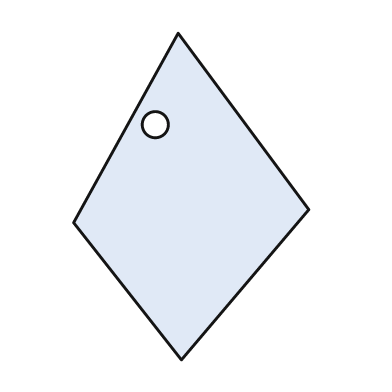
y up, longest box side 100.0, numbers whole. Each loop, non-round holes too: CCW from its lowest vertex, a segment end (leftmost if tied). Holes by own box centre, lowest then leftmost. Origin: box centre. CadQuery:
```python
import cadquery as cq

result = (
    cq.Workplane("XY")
    .moveTo(-3.0, -50.0)
    .lineTo(36.0, -4.0)
    .lineTo(-4.0, 50.0)
    .lineTo(-36.0, -8.0)
    .close()
    .moveTo(-11.0, 22.0)
    .circle(4.0)
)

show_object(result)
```